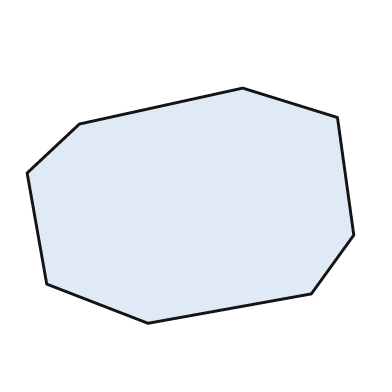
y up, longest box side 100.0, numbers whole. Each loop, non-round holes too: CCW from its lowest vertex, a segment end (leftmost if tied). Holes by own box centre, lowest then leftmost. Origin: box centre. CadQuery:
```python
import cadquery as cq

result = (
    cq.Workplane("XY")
    .moveTo(-13.0, -36.0)
    .lineTo(37.0, -27.0)
    .lineTo(50.0, -9.0)
    .lineTo(45.0, 27.0)
    .lineTo(16.0, 36.0)
    .lineTo(-34.0, 25.0)
    .lineTo(-50.0, 10.0)
    .lineTo(-44.0, -24.0)
    .close()
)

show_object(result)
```